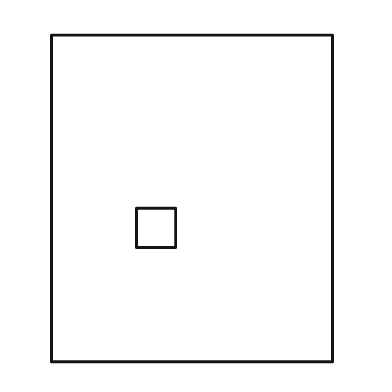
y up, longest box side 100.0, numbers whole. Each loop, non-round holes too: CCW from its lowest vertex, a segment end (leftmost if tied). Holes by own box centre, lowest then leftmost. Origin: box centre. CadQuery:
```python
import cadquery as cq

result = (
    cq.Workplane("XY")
    .moveTo(-43.0, -50.0)
    .lineTo(43.0, -50.0)
    .lineTo(43.0, 50.0)
    .lineTo(-43.0, 50.0)
    .close()
    .moveTo(-17.0, -15.0)
    .lineTo(-5.0, -15.0)
    .lineTo(-5.0, -3.0)
    .lineTo(-17.0, -3.0)
    .close()
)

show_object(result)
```